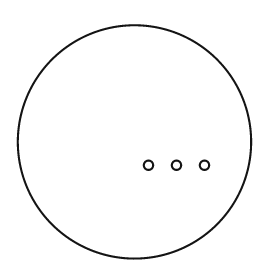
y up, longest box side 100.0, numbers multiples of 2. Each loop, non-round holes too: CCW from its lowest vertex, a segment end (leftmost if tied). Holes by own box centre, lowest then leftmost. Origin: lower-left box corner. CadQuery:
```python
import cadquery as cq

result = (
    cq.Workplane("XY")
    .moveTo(50.0, 50.0)
    .circle(50.0)
    .moveTo(56.0, 40.0)
    .circle(2.0)
    .moveTo(68.0, 40.0)
    .circle(2.0)
    .moveTo(80.0, 40.0)
    .circle(2.0)
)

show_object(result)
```